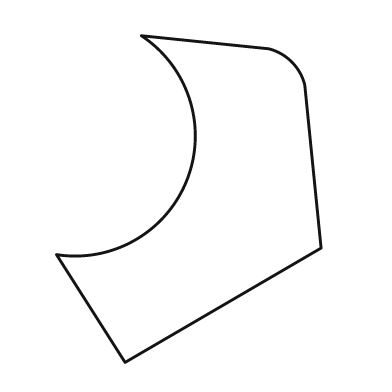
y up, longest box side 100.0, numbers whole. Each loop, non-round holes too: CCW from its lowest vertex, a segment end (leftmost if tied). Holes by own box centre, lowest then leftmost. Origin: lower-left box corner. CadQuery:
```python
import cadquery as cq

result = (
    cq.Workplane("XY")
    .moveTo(21.0, 0.0)
    .lineTo(81.0, 35.0)
    .lineTo(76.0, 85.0)
    .threePointArc((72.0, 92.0), (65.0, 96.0))
    .lineTo(26.0, 100.0)
    .threePointArc((40.0, 56.0), (0.0, 33.0))
    .close()
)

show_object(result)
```